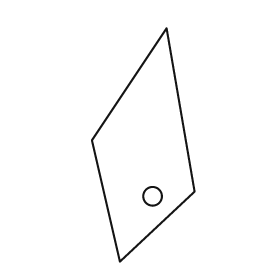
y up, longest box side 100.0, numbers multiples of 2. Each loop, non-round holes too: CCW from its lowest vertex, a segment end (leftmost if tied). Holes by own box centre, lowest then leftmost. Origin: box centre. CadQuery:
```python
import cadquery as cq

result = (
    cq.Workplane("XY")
    .moveTo(-10.0, -50.0)
    .lineTo(22.0, -20.0)
    .lineTo(10.0, 50.0)
    .lineTo(-22.0, 2.0)
    .close()
    .moveTo(4.0, -22.0)
    .circle(4.0)
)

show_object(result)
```